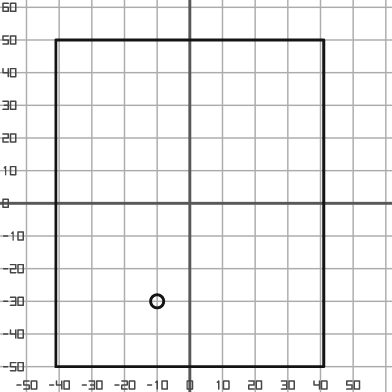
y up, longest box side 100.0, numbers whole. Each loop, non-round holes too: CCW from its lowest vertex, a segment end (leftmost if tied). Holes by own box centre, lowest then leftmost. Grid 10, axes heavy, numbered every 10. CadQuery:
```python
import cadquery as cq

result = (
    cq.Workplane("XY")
    .moveTo(-41.0, -50.0)
    .lineTo(41.0, -50.0)
    .lineTo(41.0, 50.0)
    .lineTo(-41.0, 50.0)
    .close()
    .moveTo(-10.0, -30.0)
    .circle(2.0)
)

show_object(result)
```